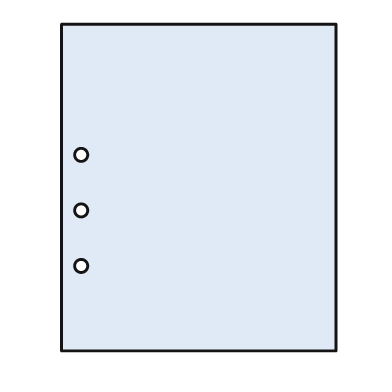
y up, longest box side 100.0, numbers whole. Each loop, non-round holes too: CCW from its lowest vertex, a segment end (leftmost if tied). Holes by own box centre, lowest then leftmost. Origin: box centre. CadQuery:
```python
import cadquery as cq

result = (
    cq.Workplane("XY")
    .moveTo(-42.0, -50.0)
    .lineTo(42.0, -50.0)
    .lineTo(42.0, 50.0)
    .lineTo(-42.0, 50.0)
    .close()
    .moveTo(-36.0, -24.0)
    .circle(2.0)
    .moveTo(-36.0, -7.0)
    .circle(2.0)
    .moveTo(-36.0, 10.0)
    .circle(2.0)
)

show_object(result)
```